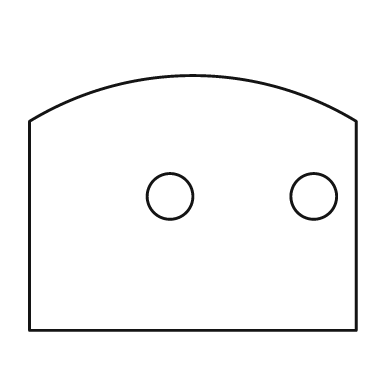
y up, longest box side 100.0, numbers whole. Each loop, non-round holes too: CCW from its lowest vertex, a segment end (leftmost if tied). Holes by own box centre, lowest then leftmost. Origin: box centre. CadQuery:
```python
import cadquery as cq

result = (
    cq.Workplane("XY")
    .moveTo(-50.0, -39.0)
    .lineTo(50.0, -39.0)
    .lineTo(50.0, 25.0)
    .threePointArc((0.0, 39.0), (-50.0, 25.0))
    .close()
    .moveTo(-7.0, 2.0)
    .circle(7.0)
    .moveTo(37.0, 2.0)
    .circle(7.0)
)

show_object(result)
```